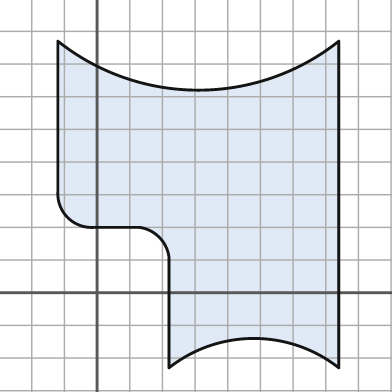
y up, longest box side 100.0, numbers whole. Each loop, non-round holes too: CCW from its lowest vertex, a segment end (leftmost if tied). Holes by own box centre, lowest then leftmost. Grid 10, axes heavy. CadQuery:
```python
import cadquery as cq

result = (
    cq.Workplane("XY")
    .moveTo(22.0, -23.0)
    .threePointArc((48.0, -14.0), (74.0, -23.0))
    .lineTo(74.0, 77.0)
    .threePointArc((31.0, 62.0), (-12.0, 77.0))
    .lineTo(-12.0, 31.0)
    .threePointArc((-9.0, 23.0), (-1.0, 20.0))
    .lineTo(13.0, 20.0)
    .threePointArc((19.0, 17.0), (22.0, 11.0))
    .close()
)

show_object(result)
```